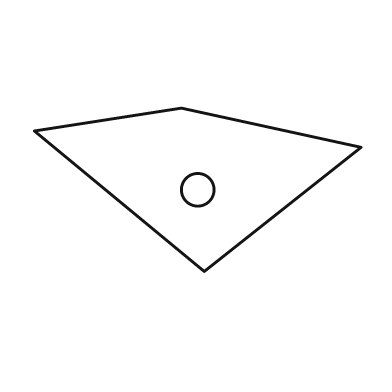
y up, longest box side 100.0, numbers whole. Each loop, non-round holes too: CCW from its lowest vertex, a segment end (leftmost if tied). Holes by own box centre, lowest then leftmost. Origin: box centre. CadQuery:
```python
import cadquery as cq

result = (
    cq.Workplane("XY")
    .moveTo(2.0, -25.0)
    .lineTo(50.0, 13.0)
    .lineTo(-5.0, 25.0)
    .lineTo(-50.0, 18.0)
    .close()
    .moveTo(0.0, 0.0)
    .circle(5.0)
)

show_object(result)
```